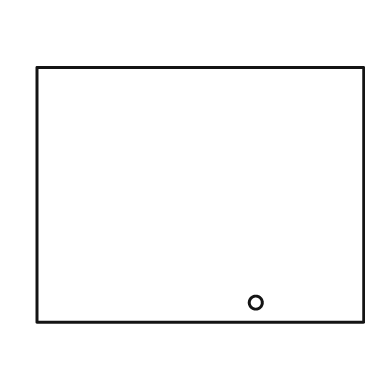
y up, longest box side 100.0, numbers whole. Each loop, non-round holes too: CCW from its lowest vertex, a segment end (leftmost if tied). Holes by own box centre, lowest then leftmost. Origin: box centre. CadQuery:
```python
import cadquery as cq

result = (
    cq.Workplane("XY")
    .moveTo(-50.0, -39.0)
    .lineTo(50.0, -39.0)
    .lineTo(50.0, 39.0)
    .lineTo(-50.0, 39.0)
    .close()
    .moveTo(17.0, -33.0)
    .circle(2.0)
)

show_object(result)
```